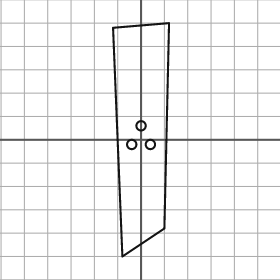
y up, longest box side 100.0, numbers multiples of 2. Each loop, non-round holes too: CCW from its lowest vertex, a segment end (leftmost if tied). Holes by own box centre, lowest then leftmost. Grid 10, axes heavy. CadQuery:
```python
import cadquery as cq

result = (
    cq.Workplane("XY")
    .moveTo(-8.0, -50.0)
    .lineTo(10.0, -38.0)
    .lineTo(12.0, 50.0)
    .lineTo(-12.0, 48.0)
    .close()
    .moveTo(-4.0, -2.0)
    .circle(2.0)
    .moveTo(4.0, -2.0)
    .circle(2.0)
    .moveTo(0.0, 6.0)
    .circle(2.0)
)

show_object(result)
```